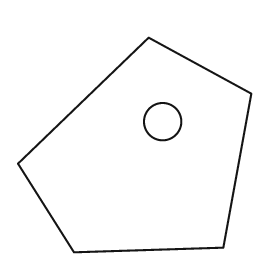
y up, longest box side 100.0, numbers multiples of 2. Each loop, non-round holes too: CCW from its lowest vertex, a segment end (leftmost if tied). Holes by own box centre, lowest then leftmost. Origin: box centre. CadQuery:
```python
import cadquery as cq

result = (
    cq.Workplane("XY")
    .moveTo(-26.0, -46.0)
    .lineTo(38.0, -44.0)
    .lineTo(50.0, 22.0)
    .lineTo(6.0, 46.0)
    .lineTo(-50.0, -8.0)
    .close()
    .moveTo(12.0, 10.0)
    .circle(8.0)
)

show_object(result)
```